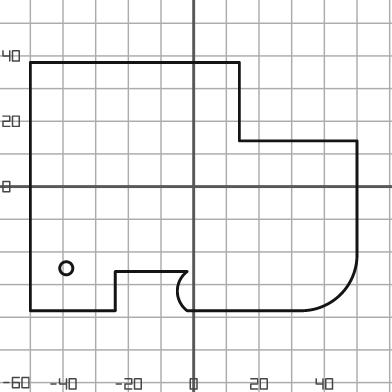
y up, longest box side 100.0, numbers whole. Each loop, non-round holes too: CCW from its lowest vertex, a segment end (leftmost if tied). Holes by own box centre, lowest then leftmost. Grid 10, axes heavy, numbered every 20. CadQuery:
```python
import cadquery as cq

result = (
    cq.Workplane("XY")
    .moveTo(-50.0, -38.0)
    .lineTo(-24.0, -38.0)
    .lineTo(-24.0, -26.0)
    .lineTo(-2.0, -26.0)
    .threePointArc((-5.0, -32.0), (-2.0, -38.0))
    .lineTo(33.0, -38.0)
    .threePointArc((45.0, -33.0), (50.0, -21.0))
    .lineTo(50.0, 14.0)
    .lineTo(14.0, 14.0)
    .lineTo(14.0, 38.0)
    .lineTo(-50.0, 38.0)
    .close()
    .moveTo(-39.0, -25.0)
    .circle(2.0)
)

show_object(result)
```